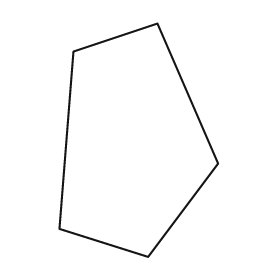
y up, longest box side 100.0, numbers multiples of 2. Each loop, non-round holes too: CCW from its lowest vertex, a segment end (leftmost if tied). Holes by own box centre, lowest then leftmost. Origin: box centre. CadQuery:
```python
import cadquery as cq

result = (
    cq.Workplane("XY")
    .moveTo(4.0, -50.0)
    .lineTo(34.0, -10.0)
    .lineTo(8.0, 50.0)
    .lineTo(-28.0, 38.0)
    .lineTo(-34.0, -38.0)
    .close()
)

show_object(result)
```